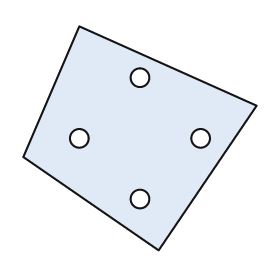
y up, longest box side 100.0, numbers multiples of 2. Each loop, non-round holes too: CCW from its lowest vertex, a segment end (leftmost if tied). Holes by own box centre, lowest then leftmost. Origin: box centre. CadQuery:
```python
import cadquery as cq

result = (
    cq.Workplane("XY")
    .moveTo(8.0, -48.0)
    .lineTo(50.0, 14.0)
    .lineTo(-26.0, 48.0)
    .lineTo(-50.0, -8.0)
    .close()
    .moveTo(0.0, -26.0)
    .circle(4.0)
    .moveTo(-26.0, 0.0)
    .circle(4.0)
    .moveTo(26.0, 0.0)
    .circle(4.0)
    .moveTo(0.0, 26.0)
    .circle(4.0)
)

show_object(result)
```